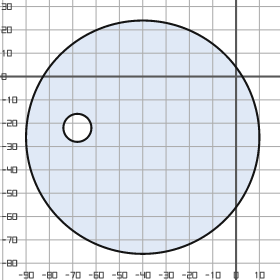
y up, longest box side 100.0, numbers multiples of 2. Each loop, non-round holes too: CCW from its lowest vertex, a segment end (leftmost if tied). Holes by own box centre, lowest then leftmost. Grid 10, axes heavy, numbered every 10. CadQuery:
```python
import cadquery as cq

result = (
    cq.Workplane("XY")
    .moveTo(-40.0, -26.0)
    .circle(50.0)
    .moveTo(-68.0, -22.0)
    .circle(6.0)
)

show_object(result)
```